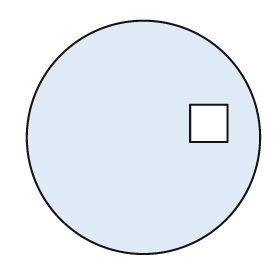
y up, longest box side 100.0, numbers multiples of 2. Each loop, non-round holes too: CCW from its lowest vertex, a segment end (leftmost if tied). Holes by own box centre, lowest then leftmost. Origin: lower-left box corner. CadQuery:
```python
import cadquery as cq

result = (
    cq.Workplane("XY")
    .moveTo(50.0, 50.0)
    .circle(50.0)
    .moveTo(70.0, 48.0)
    .lineTo(86.0, 48.0)
    .lineTo(86.0, 64.0)
    .lineTo(70.0, 64.0)
    .close()
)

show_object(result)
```